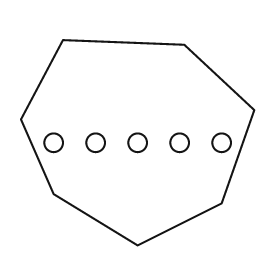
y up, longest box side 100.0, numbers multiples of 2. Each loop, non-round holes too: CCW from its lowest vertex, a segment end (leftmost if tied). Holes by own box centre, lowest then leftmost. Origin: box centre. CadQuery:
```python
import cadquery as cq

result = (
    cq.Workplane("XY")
    .moveTo(0.0, -44.0)
    .lineTo(36.0, -26.0)
    .lineTo(50.0, 14.0)
    .lineTo(20.0, 42.0)
    .lineTo(-32.0, 44.0)
    .lineTo(-50.0, 10.0)
    .lineTo(-36.0, -22.0)
    .close()
    .moveTo(-36.0, 0.0)
    .circle(4.0)
    .moveTo(-18.0, 0.0)
    .circle(4.0)
    .moveTo(0.0, 0.0)
    .circle(4.0)
    .moveTo(18.0, 0.0)
    .circle(4.0)
    .moveTo(36.0, 0.0)
    .circle(4.0)
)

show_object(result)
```